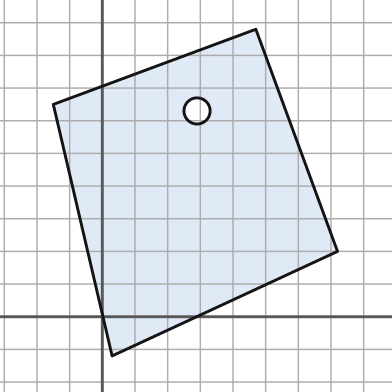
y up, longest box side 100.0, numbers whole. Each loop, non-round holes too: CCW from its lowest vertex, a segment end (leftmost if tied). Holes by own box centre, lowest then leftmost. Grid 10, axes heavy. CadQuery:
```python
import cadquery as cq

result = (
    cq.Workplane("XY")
    .moveTo(3.0, -12.0)
    .lineTo(72.0, 20.0)
    .lineTo(47.0, 88.0)
    .lineTo(-15.0, 65.0)
    .close()
    .moveTo(29.0, 63.0)
    .circle(4.0)
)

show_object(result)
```